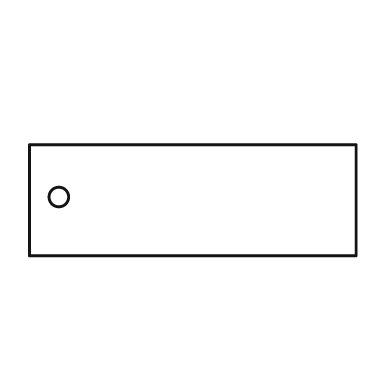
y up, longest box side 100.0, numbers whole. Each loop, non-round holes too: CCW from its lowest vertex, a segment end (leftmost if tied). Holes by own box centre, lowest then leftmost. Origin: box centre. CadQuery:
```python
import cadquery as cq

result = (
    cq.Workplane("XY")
    .moveTo(-50.0, -17.0)
    .lineTo(50.0, -17.0)
    .lineTo(50.0, 17.0)
    .lineTo(-50.0, 17.0)
    .close()
    .moveTo(-41.0, 1.0)
    .circle(3.0)
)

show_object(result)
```